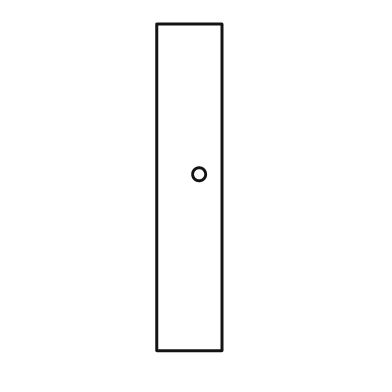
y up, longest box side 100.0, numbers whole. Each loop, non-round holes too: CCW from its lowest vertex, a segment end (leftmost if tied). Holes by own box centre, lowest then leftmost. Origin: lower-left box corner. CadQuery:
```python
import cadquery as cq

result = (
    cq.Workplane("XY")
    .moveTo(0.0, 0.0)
    .lineTo(20.0, 0.0)
    .lineTo(20.0, 100.0)
    .lineTo(0.0, 100.0)
    .close()
    .moveTo(13.0, 54.0)
    .circle(2.0)
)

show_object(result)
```